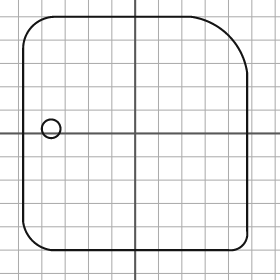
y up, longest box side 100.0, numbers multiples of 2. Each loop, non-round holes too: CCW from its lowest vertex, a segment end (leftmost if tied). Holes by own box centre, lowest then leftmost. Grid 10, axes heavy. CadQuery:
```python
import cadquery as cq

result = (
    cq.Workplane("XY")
    .moveTo(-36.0, -50.0)
    .lineTo(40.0, -50.0)
    .threePointArc((46.0, -48.0), (48.0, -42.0))
    .lineTo(48.0, 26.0)
    .threePointArc((40.0, 42.0), (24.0, 50.0))
    .lineTo(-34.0, 50.0)
    .threePointArc((-44.0, 46.0), (-48.0, 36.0))
    .lineTo(-48.0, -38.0)
    .threePointArc((-44.0, -46.0), (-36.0, -50.0))
    .close()
    .moveTo(-36.0, 2.0)
    .circle(4.0)
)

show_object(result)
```